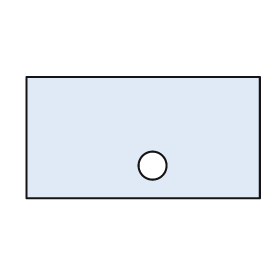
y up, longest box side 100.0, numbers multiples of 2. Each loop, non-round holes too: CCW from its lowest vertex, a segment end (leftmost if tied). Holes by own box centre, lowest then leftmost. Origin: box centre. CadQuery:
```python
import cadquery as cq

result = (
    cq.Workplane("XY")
    .moveTo(-50.0, -26.0)
    .lineTo(50.0, -26.0)
    .lineTo(50.0, 26.0)
    .lineTo(-50.0, 26.0)
    .close()
    .moveTo(4.0, -12.0)
    .circle(6.0)
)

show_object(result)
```